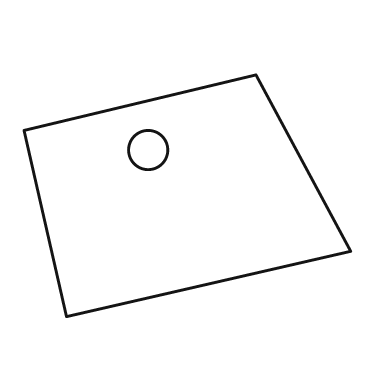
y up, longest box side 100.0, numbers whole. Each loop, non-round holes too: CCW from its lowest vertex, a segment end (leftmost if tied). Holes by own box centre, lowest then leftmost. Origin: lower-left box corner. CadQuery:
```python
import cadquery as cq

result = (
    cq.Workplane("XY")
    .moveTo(13.0, 0.0)
    .lineTo(100.0, 20.0)
    .lineTo(71.0, 74.0)
    .lineTo(0.0, 57.0)
    .close()
    .moveTo(38.0, 51.0)
    .circle(6.0)
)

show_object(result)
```